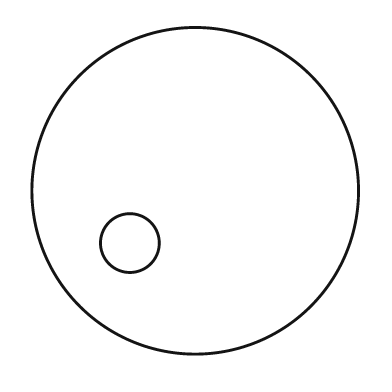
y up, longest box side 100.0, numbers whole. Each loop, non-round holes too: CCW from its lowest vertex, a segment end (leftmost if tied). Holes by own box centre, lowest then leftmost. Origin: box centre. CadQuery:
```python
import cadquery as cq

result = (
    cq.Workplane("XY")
    .moveTo(0.0, 0.0)
    .circle(50.0)
    .moveTo(-20.0, -16.0)
    .circle(9.0)
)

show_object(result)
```